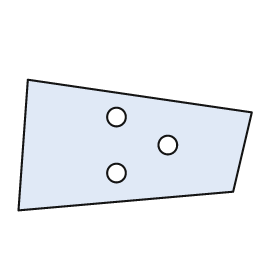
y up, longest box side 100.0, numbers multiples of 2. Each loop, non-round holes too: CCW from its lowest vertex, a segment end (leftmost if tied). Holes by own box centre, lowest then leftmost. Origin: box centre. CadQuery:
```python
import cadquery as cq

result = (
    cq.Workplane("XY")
    .moveTo(-50.0, -28.0)
    .lineTo(42.0, -20.0)
    .lineTo(50.0, 14.0)
    .lineTo(-46.0, 28.0)
    .close()
    .moveTo(-8.0, -12.0)
    .circle(4.0)
    .moveTo(14.0, 0.0)
    .circle(4.0)
    .moveTo(-8.0, 12.0)
    .circle(4.0)
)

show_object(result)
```